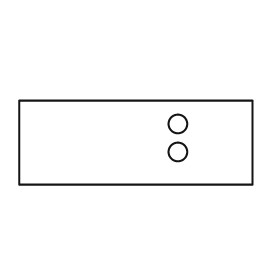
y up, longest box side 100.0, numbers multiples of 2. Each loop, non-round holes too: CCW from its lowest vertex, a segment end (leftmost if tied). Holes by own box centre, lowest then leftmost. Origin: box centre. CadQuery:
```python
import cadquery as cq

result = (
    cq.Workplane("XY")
    .moveTo(-50.0, -18.0)
    .lineTo(50.0, -18.0)
    .lineTo(50.0, 18.0)
    .lineTo(-50.0, 18.0)
    .close()
    .moveTo(18.0, -4.0)
    .circle(4.0)
    .moveTo(18.0, 8.0)
    .circle(4.0)
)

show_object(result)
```